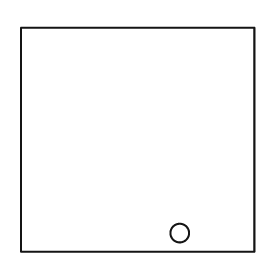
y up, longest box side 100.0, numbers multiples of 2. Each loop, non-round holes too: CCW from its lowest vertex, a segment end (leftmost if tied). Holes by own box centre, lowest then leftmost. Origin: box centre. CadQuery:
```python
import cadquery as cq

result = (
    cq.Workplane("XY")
    .moveTo(-50.0, -48.0)
    .lineTo(50.0, -48.0)
    .lineTo(50.0, 48.0)
    .lineTo(-50.0, 48.0)
    .close()
    .moveTo(18.0, -40.0)
    .circle(4.0)
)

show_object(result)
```